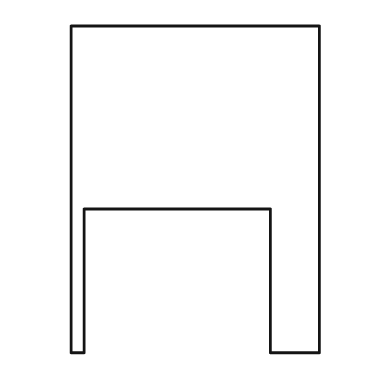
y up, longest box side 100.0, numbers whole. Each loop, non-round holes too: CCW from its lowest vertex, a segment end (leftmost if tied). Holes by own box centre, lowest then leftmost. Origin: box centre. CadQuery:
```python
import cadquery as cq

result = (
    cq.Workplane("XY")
    .moveTo(-38.0, -50.0)
    .lineTo(-34.0, -50.0)
    .lineTo(-34.0, -6.0)
    .lineTo(23.0, -6.0)
    .lineTo(23.0, -50.0)
    .lineTo(38.0, -50.0)
    .lineTo(38.0, 50.0)
    .lineTo(-38.0, 50.0)
    .close()
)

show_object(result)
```